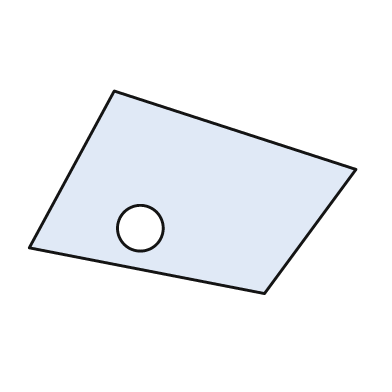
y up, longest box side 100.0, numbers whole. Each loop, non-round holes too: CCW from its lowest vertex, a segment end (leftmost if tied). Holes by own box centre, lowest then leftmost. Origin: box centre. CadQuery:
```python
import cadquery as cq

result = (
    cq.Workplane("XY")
    .moveTo(22.0, -31.0)
    .lineTo(50.0, 7.0)
    .lineTo(-24.0, 31.0)
    .lineTo(-50.0, -17.0)
    .close()
    .moveTo(-16.0, -11.0)
    .circle(7.0)
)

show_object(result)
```